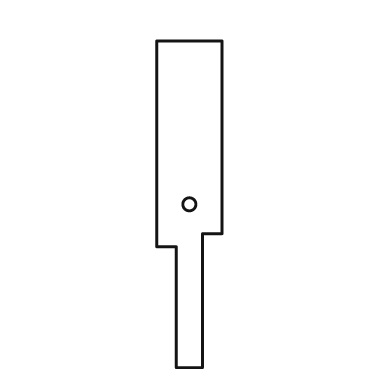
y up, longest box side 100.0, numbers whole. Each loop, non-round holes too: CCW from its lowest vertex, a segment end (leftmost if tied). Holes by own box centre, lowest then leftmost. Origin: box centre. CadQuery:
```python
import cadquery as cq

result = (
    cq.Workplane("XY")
    .moveTo(-4.0, -50.0)
    .lineTo(4.0, -50.0)
    .lineTo(4.0, -9.0)
    .lineTo(10.0, -9.0)
    .lineTo(10.0, 50.0)
    .lineTo(-10.0, 50.0)
    .lineTo(-10.0, -13.0)
    .lineTo(-4.0, -13.0)
    .close()
    .moveTo(0.0, 0.0)
    .circle(2.0)
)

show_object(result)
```